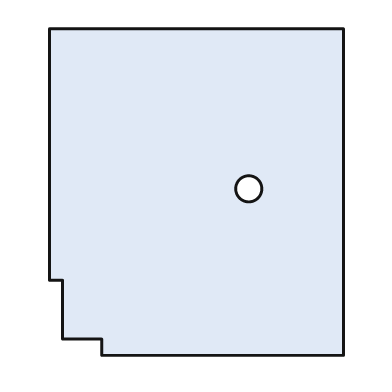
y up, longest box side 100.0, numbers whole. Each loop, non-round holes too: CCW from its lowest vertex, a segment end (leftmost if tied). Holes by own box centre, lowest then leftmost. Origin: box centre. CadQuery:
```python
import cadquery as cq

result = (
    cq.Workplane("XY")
    .moveTo(-29.0, -50.0)
    .lineTo(45.0, -50.0)
    .lineTo(45.0, 50.0)
    .lineTo(-45.0, 50.0)
    .lineTo(-45.0, -27.0)
    .lineTo(-41.0, -27.0)
    .lineTo(-41.0, -45.0)
    .lineTo(-29.0, -45.0)
    .close()
    .moveTo(16.0, 1.0)
    .circle(4.0)
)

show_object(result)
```